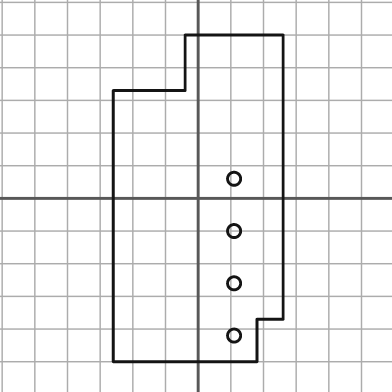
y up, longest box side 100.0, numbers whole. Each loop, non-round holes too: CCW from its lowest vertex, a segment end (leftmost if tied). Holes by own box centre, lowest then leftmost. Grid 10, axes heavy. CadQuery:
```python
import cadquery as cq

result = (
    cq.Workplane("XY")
    .moveTo(-26.0, -50.0)
    .lineTo(18.0, -50.0)
    .lineTo(18.0, -37.0)
    .lineTo(26.0, -37.0)
    .lineTo(26.0, 50.0)
    .lineTo(-4.0, 50.0)
    .lineTo(-4.0, 33.0)
    .lineTo(-26.0, 33.0)
    .close()
    .moveTo(11.0, -42.0)
    .circle(2.0)
    .moveTo(11.0, -26.0)
    .circle(2.0)
    .moveTo(11.0, -10.0)
    .circle(2.0)
    .moveTo(11.0, 6.0)
    .circle(2.0)
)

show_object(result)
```